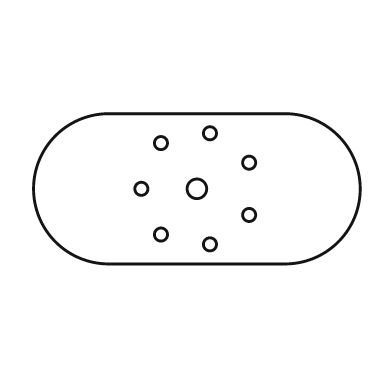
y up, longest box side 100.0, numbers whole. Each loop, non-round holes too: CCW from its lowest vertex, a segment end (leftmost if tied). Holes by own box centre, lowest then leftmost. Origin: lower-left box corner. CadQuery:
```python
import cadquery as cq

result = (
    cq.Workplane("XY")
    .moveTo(23.0, 0.0)
    .lineTo(77.0, 0.0)
    .threePointArc((100.0, 23.0), (77.0, 46.0))
    .lineTo(23.0, 46.0)
    .threePointArc((0.0, 23.0), (23.0, 0.0))
    .close()
    .moveTo(54.0, 6.0)
    .circle(2.0)
    .moveTo(39.0, 9.0)
    .circle(2.0)
    .moveTo(66.0, 15.0)
    .circle(2.0)
    .moveTo(33.0, 23.0)
    .circle(2.0)
    .moveTo(50.0, 23.0)
    .circle(3.0)
    .moveTo(66.0, 31.0)
    .circle(2.0)
    .moveTo(39.0, 37.0)
    .circle(2.0)
    .moveTo(54.0, 40.0)
    .circle(2.0)
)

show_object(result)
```